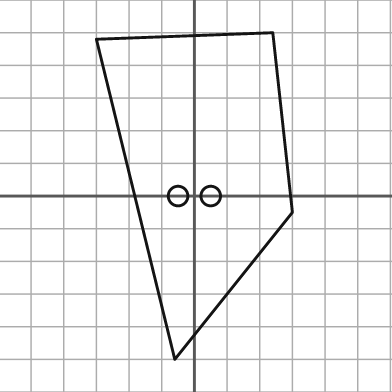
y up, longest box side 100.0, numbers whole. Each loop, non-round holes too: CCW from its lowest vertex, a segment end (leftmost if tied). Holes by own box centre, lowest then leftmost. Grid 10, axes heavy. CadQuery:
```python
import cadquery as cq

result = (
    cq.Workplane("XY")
    .moveTo(-6.0, -50.0)
    .lineTo(30.0, -5.0)
    .lineTo(24.0, 50.0)
    .lineTo(-30.0, 48.0)
    .close()
    .moveTo(-5.0, 0.0)
    .circle(3.0)
    .moveTo(5.0, 0.0)
    .circle(3.0)
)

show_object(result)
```